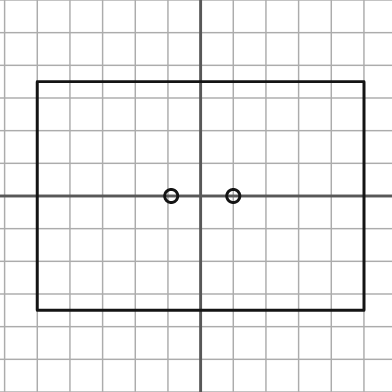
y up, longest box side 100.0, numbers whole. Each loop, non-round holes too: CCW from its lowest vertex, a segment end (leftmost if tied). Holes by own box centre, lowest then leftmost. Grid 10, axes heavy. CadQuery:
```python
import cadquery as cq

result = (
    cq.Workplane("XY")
    .moveTo(-50.0, -35.0)
    .lineTo(50.0, -35.0)
    .lineTo(50.0, 35.0)
    .lineTo(-50.0, 35.0)
    .close()
    .moveTo(-9.0, 0.0)
    .circle(2.0)
    .moveTo(10.0, 0.0)
    .circle(2.0)
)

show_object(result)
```